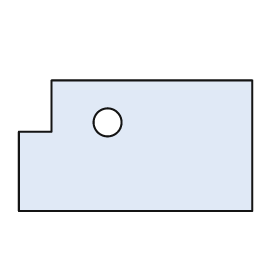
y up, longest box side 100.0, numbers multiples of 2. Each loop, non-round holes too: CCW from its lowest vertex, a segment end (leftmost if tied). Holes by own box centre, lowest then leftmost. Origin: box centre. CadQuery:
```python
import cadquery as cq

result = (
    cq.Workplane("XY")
    .moveTo(-50.0, -28.0)
    .lineTo(50.0, -28.0)
    .lineTo(50.0, 28.0)
    .lineTo(-36.0, 28.0)
    .lineTo(-36.0, 6.0)
    .lineTo(-50.0, 6.0)
    .close()
    .moveTo(-12.0, 10.0)
    .circle(6.0)
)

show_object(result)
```